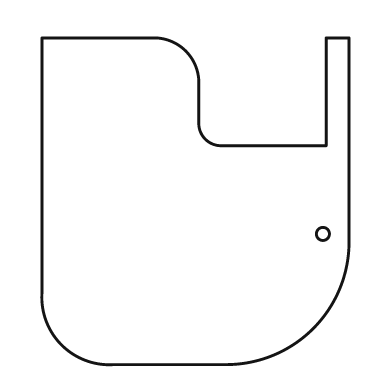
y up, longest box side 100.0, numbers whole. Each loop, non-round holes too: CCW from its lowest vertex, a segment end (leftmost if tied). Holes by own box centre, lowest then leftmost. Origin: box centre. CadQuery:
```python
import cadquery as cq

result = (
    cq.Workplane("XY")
    .moveTo(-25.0, -50.0)
    .lineTo(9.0, -50.0)
    .threePointArc((36.0, -39.0), (47.0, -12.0))
    .lineTo(47.0, 50.0)
    .lineTo(40.0, 50.0)
    .lineTo(40.0, 17.0)
    .lineTo(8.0, 17.0)
    .threePointArc((3.0, 19.0), (1.0, 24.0))
    .lineTo(1.0, 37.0)
    .threePointArc((-3.0, 46.0), (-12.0, 50.0))
    .lineTo(-47.0, 50.0)
    .lineTo(-47.0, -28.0)
    .threePointArc((-41.0, -44.0), (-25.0, -50.0))
    .close()
    .moveTo(39.0, -10.0)
    .circle(2.0)
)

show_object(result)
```